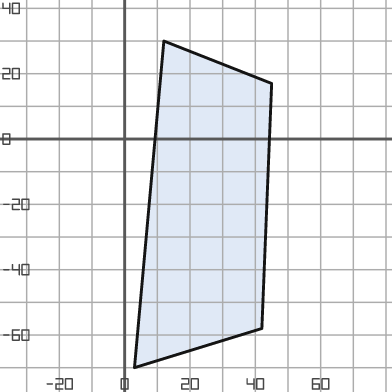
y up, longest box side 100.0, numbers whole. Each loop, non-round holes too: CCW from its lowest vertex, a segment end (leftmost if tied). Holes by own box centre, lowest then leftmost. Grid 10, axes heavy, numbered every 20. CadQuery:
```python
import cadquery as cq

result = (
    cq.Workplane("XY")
    .moveTo(3.0, -70.0)
    .lineTo(42.0, -58.0)
    .lineTo(45.0, 17.0)
    .lineTo(12.0, 30.0)
    .close()
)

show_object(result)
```